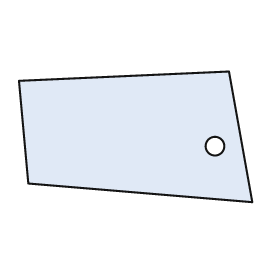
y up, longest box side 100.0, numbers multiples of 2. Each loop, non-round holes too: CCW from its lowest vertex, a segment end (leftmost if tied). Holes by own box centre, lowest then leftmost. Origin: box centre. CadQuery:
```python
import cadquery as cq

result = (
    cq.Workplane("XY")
    .moveTo(50.0, -28.0)
    .lineTo(40.0, 28.0)
    .lineTo(-50.0, 24.0)
    .lineTo(-46.0, -20.0)
    .close()
    .moveTo(34.0, -4.0)
    .circle(4.0)
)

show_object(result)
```